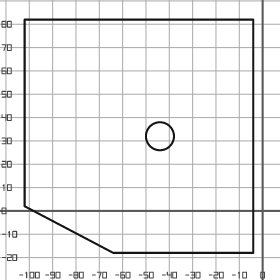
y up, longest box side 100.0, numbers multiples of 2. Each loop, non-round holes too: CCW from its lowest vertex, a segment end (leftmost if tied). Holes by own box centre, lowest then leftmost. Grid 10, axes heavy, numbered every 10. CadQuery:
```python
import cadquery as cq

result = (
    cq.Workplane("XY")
    .moveTo(-64.0, -18.0)
    .lineTo(-4.0, -18.0)
    .lineTo(-4.0, 82.0)
    .lineTo(-102.0, 82.0)
    .lineTo(-102.0, 2.0)
    .close()
    .moveTo(-44.0, 32.0)
    .circle(6.0)
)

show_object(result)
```